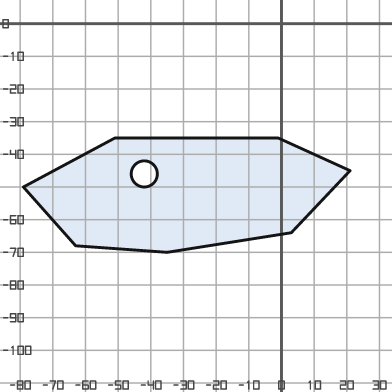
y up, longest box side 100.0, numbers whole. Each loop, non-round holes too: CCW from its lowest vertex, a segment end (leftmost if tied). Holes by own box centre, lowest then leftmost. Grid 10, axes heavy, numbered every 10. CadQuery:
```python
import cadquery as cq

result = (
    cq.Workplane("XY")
    .moveTo(-35.0, -70.0)
    .lineTo(3.0, -64.0)
    .lineTo(21.0, -45.0)
    .lineTo(-1.0, -35.0)
    .lineTo(-51.0, -35.0)
    .lineTo(-79.0, -50.0)
    .lineTo(-63.0, -68.0)
    .close()
    .moveTo(-42.0, -46.0)
    .circle(4.0)
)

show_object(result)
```